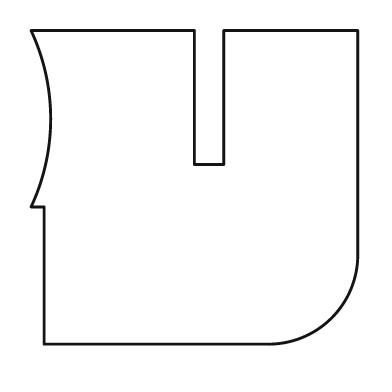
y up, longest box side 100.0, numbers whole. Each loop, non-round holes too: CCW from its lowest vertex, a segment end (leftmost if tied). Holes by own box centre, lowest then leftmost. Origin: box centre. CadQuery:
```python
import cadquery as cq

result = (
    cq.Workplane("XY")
    .moveTo(-46.0, -48.0)
    .lineTo(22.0, -48.0)
    .threePointArc((42.0, -40.0), (50.0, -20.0))
    .lineTo(50.0, 48.0)
    .lineTo(9.0, 48.0)
    .lineTo(9.0, 7.0)
    .lineTo(0.0, 7.0)
    .lineTo(0.0, 48.0)
    .lineTo(-50.0, 48.0)
    .threePointArc((-44.0, 21.0), (-50.0, -6.0))
    .lineTo(-46.0, -6.0)
    .close()
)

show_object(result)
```